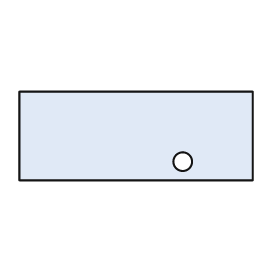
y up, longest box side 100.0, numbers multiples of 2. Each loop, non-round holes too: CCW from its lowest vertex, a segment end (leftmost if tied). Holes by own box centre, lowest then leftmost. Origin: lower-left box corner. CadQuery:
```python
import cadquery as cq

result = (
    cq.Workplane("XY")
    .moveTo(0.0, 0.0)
    .lineTo(100.0, 0.0)
    .lineTo(100.0, 38.0)
    .lineTo(0.0, 38.0)
    .close()
    .moveTo(70.0, 8.0)
    .circle(4.0)
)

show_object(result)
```